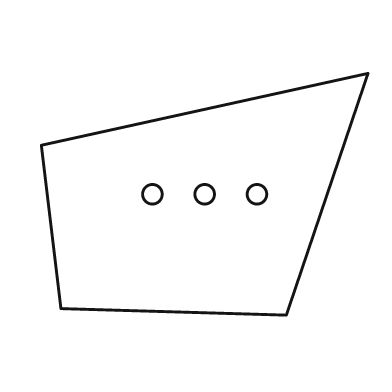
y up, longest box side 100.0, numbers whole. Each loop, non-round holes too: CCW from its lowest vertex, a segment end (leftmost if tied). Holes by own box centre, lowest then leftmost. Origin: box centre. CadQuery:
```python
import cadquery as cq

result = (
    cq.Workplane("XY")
    .moveTo(25.0, -37.0)
    .lineTo(50.0, 37.0)
    .lineTo(-50.0, 15.0)
    .lineTo(-44.0, -35.0)
    .close()
    .moveTo(-16.0, 0.0)
    .circle(3.0)
    .moveTo(0.0, 0.0)
    .circle(3.0)
    .moveTo(16.0, 0.0)
    .circle(3.0)
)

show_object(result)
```